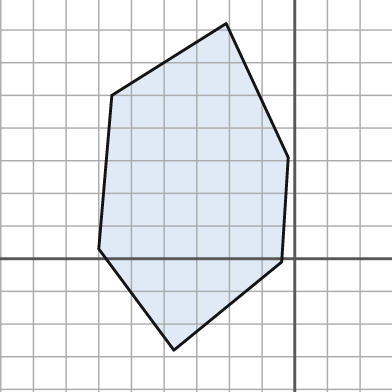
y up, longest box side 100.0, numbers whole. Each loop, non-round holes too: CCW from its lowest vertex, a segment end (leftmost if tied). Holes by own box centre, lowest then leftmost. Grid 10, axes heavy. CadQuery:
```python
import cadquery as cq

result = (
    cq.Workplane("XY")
    .moveTo(-37.0, -28.0)
    .lineTo(-4.0, -1.0)
    .lineTo(-2.0, 31.0)
    .lineTo(-21.0, 72.0)
    .lineTo(-56.0, 50.0)
    .lineTo(-60.0, 3.0)
    .close()
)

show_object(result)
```